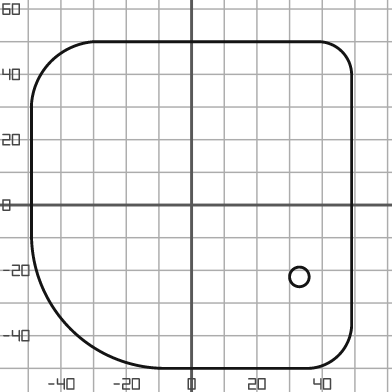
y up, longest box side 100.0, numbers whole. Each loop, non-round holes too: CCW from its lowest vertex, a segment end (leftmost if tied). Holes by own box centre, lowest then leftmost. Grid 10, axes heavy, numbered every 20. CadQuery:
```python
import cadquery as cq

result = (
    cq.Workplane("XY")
    .moveTo(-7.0, -50.0)
    .lineTo(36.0, -50.0)
    .threePointArc((45.0, -46.0), (49.0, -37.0))
    .lineTo(49.0, 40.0)
    .threePointArc((46.0, 47.0), (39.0, 50.0))
    .lineTo(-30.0, 50.0)
    .threePointArc((-43.0, 44.0), (-49.0, 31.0))
    .lineTo(-49.0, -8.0)
    .threePointArc((-37.0, -38.0), (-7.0, -50.0))
    .close()
    .moveTo(33.0, -22.0)
    .circle(3.0)
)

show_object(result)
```